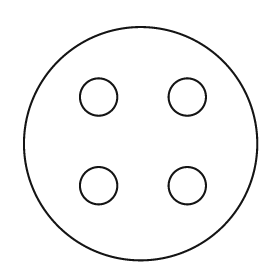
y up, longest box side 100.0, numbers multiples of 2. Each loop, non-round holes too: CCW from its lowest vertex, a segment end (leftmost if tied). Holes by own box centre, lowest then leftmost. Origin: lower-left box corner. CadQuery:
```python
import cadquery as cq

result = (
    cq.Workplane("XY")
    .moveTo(50.0, 50.0)
    .circle(50.0)
    .moveTo(32.0, 32.0)
    .circle(8.0)
    .moveTo(70.0, 32.0)
    .circle(8.0)
    .moveTo(32.0, 70.0)
    .circle(8.0)
    .moveTo(70.0, 70.0)
    .circle(8.0)
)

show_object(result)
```